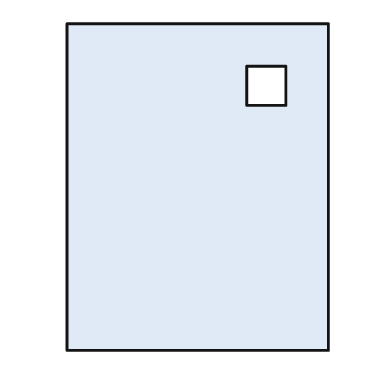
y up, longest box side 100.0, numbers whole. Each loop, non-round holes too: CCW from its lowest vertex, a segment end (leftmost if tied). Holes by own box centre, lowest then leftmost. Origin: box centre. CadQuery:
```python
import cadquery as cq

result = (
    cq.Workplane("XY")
    .moveTo(-40.0, -50.0)
    .lineTo(40.0, -50.0)
    .lineTo(40.0, 50.0)
    .lineTo(-40.0, 50.0)
    .close()
    .moveTo(15.0, 25.0)
    .lineTo(27.0, 25.0)
    .lineTo(27.0, 37.0)
    .lineTo(15.0, 37.0)
    .close()
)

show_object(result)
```